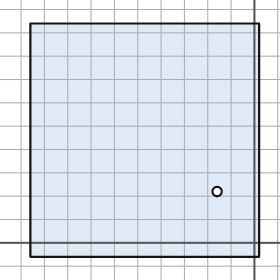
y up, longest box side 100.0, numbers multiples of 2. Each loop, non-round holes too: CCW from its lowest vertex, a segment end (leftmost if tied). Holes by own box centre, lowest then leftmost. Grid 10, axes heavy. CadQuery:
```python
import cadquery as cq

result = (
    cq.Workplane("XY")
    .moveTo(-96.0, -6.0)
    .lineTo(2.0, -6.0)
    .lineTo(2.0, 94.0)
    .lineTo(-96.0, 94.0)
    .close()
    .moveTo(-16.0, 22.0)
    .circle(2.0)
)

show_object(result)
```